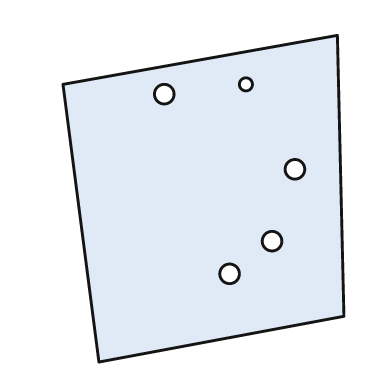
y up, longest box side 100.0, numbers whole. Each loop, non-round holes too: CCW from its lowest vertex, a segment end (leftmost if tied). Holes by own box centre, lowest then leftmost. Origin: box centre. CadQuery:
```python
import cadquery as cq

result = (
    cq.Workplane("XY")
    .moveTo(-32.0, -50.0)
    .lineTo(43.0, -36.0)
    .lineTo(41.0, 50.0)
    .lineTo(-43.0, 35.0)
    .close()
    .moveTo(8.0, -23.0)
    .circle(3.0)
    .moveTo(21.0, -13.0)
    .circle(3.0)
    .moveTo(28.0, 9.0)
    .circle(3.0)
    .moveTo(-12.0, 32.0)
    .circle(3.0)
    .moveTo(13.0, 35.0)
    .circle(2.0)
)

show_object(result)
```